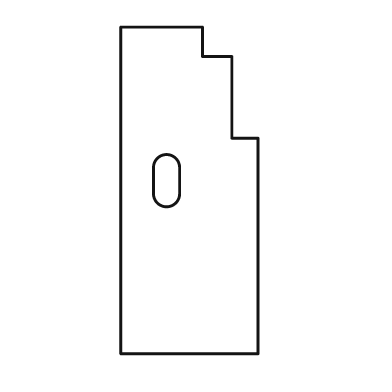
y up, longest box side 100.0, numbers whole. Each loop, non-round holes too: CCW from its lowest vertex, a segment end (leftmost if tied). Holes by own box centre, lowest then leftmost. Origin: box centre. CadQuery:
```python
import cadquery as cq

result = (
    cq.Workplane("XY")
    .moveTo(-21.0, -50.0)
    .lineTo(21.0, -50.0)
    .lineTo(21.0, 16.0)
    .lineTo(13.0, 16.0)
    .lineTo(13.0, 41.0)
    .lineTo(4.0, 41.0)
    .lineTo(4.0, 50.0)
    .lineTo(-21.0, 50.0)
    .close()
    .moveTo(-11.0, -1.0)
    .threePointArc((-7.0, -5.0), (-3.0, -1.0))
    .lineTo(-3.0, 7.0)
    .threePointArc((-7.0, 11.0), (-11.0, 7.0))
    .close()
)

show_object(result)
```